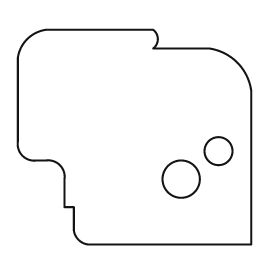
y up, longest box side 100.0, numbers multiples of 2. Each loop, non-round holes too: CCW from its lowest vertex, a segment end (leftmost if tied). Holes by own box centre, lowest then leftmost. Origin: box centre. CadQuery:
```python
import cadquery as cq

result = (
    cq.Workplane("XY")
    .moveTo(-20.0, -46.0)
    .lineTo(50.0, -46.0)
    .lineTo(50.0, 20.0)
    .threePointArc((44.0, 32.0), (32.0, 38.0))
    .lineTo(8.0, 38.0)
    .threePointArc((10.0, 42.0), (8.0, 46.0))
    .lineTo(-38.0, 46.0)
    .threePointArc((-46.0, 42.0), (-50.0, 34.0))
    .lineTo(-50.0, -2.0)
    .threePointArc((-48.0, -8.0), (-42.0, -10.0))
    .lineTo(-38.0, -10.0)
    .threePointArc((-32.0, -12.0), (-30.0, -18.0))
    .lineTo(-30.0, -30.0)
    .lineTo(-26.0, -30.0)
    .lineTo(-26.0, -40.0)
    .threePointArc((-24.0, -44.0), (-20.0, -46.0))
    .close()
    .moveTo(20.0, -18.0)
    .circle(8.0)
    .moveTo(36.0, -6.0)
    .circle(6.0)
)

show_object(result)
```